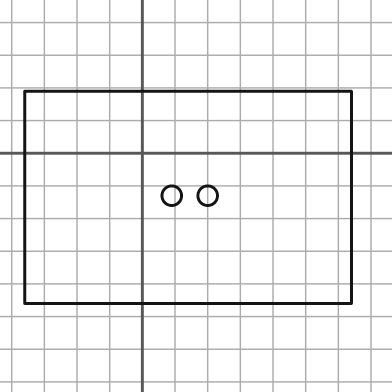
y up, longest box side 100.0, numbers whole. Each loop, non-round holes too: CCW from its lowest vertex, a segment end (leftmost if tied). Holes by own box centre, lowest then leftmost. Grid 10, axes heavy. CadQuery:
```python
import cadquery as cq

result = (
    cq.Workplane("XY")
    .moveTo(-36.0, -46.0)
    .lineTo(64.0, -46.0)
    .lineTo(64.0, 19.0)
    .lineTo(-36.0, 19.0)
    .close()
    .moveTo(9.0, -13.0)
    .circle(3.0)
    .moveTo(20.0, -13.0)
    .circle(3.0)
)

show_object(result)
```